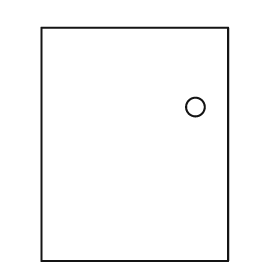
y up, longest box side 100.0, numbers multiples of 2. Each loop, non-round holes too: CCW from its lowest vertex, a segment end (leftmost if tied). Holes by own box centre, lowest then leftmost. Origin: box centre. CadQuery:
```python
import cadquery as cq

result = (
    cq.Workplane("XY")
    .moveTo(-40.0, -50.0)
    .lineTo(40.0, -50.0)
    .lineTo(40.0, 50.0)
    .lineTo(-40.0, 50.0)
    .close()
    .moveTo(26.0, 16.0)
    .circle(4.0)
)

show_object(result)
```